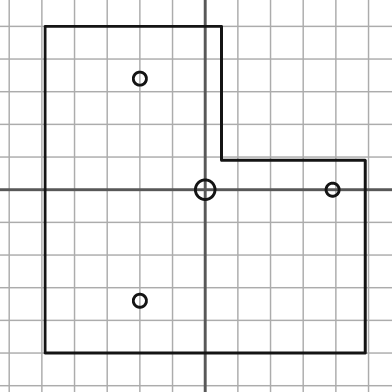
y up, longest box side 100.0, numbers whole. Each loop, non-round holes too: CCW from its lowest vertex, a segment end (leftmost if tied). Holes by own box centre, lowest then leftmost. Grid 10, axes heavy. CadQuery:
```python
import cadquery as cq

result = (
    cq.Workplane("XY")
    .moveTo(-49.0, -50.0)
    .lineTo(49.0, -50.0)
    .lineTo(49.0, 9.0)
    .lineTo(5.0, 9.0)
    .lineTo(5.0, 50.0)
    .lineTo(-49.0, 50.0)
    .close()
    .moveTo(-20.0, -34.0)
    .circle(2.0)
    .moveTo(0.0, 0.0)
    .circle(3.0)
    .moveTo(39.0, 0.0)
    .circle(2.0)
    .moveTo(-20.0, 34.0)
    .circle(2.0)
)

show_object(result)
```